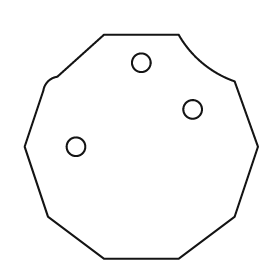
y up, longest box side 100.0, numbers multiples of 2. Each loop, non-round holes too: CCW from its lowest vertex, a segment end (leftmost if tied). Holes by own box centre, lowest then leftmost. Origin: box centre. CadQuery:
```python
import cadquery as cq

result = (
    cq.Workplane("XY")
    .moveTo(-16.0, -48.0)
    .lineTo(16.0, -48.0)
    .lineTo(40.0, -30.0)
    .lineTo(50.0, 0.0)
    .lineTo(40.0, 28.0)
    .threePointArc((26.0, 36.0), (16.0, 48.0))
    .lineTo(-16.0, 48.0)
    .lineTo(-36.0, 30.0)
    .threePointArc((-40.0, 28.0), (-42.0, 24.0))
    .lineTo(-50.0, 0.0)
    .lineTo(-40.0, -30.0)
    .close()
    .moveTo(-28.0, 0.0)
    .circle(4.0)
    .moveTo(22.0, 16.0)
    .circle(4.0)
    .moveTo(0.0, 36.0)
    .circle(4.0)
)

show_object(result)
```